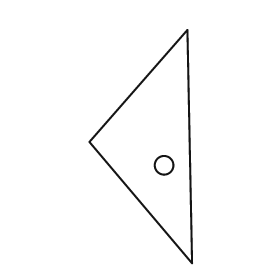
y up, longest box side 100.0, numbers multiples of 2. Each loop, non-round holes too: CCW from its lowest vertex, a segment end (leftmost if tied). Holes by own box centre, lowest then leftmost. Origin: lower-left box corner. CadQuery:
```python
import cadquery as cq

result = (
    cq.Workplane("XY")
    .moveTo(44.0, 0.0)
    .lineTo(42.0, 100.0)
    .lineTo(0.0, 52.0)
    .close()
    .moveTo(32.0, 42.0)
    .circle(4.0)
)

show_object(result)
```